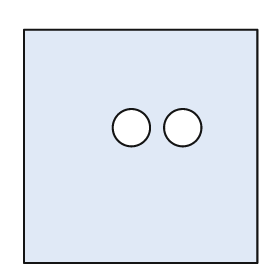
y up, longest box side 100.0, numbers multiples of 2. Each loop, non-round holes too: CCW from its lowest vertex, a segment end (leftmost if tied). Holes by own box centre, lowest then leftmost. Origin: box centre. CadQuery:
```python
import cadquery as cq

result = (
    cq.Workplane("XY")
    .moveTo(-50.0, -50.0)
    .lineTo(50.0, -50.0)
    .lineTo(50.0, 50.0)
    .lineTo(-50.0, 50.0)
    .close()
    .moveTo(-4.0, 8.0)
    .circle(8.0)
    .moveTo(18.0, 8.0)
    .circle(8.0)
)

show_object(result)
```